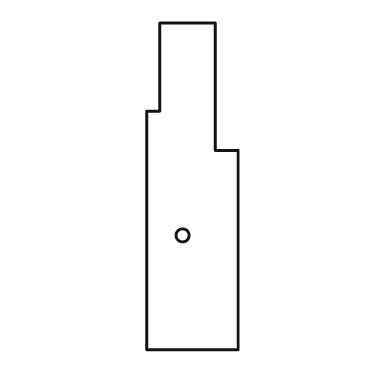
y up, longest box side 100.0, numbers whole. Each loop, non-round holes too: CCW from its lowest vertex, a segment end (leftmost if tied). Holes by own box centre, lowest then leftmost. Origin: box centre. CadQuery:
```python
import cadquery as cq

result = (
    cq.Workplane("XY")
    .moveTo(-14.0, -50.0)
    .lineTo(14.0, -50.0)
    .lineTo(14.0, 11.0)
    .lineTo(7.0, 11.0)
    .lineTo(7.0, 50.0)
    .lineTo(-10.0, 50.0)
    .lineTo(-10.0, 23.0)
    .lineTo(-14.0, 23.0)
    .close()
    .moveTo(-3.0, -15.0)
    .circle(2.0)
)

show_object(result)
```